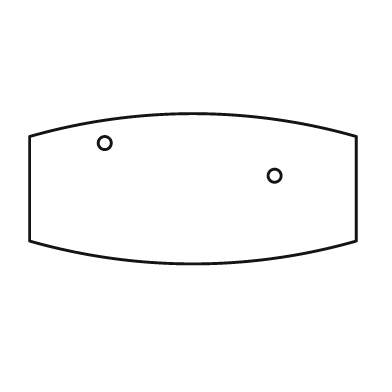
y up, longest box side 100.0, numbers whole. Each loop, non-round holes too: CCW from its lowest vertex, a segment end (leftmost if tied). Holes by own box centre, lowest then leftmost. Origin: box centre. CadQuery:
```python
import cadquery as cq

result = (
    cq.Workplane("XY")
    .moveTo(-50.0, -16.0)
    .threePointArc((0.0, -23.0), (50.0, -16.0))
    .lineTo(50.0, 16.0)
    .threePointArc((0.0, 23.0), (-50.0, 16.0))
    .close()
    .moveTo(25.0, 4.0)
    .circle(2.0)
    .moveTo(-27.0, 14.0)
    .circle(2.0)
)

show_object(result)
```